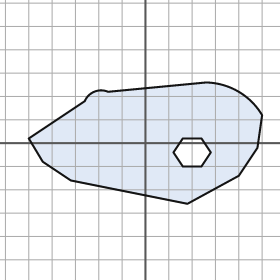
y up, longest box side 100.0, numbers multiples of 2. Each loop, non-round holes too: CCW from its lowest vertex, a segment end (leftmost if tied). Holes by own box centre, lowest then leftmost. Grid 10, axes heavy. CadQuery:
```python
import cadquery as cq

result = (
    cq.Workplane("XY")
    .moveTo(18.0, -26.0)
    .lineTo(40.0, -14.0)
    .lineTo(48.0, -2.0)
    .lineTo(50.0, 12.0)
    .threePointArc((40.0, 22.0), (26.0, 26.0))
    .lineTo(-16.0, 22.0)
    .threePointArc((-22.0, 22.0), (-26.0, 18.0))
    .lineTo(-50.0, 2.0)
    .lineTo(-44.0, -8.0)
    .lineTo(-32.0, -16.0)
    .close()
    .moveTo(16.0, -10.0)
    .lineTo(24.0, -10.0)
    .lineTo(28.0, -4.0)
    .lineTo(24.0, 2.0)
    .lineTo(16.0, 2.0)
    .lineTo(12.0, -4.0)
    .close()
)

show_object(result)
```